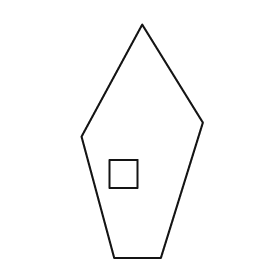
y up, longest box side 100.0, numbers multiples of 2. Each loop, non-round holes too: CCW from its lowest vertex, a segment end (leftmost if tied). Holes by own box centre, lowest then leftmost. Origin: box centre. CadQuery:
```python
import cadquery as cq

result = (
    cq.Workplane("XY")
    .moveTo(-12.0, -50.0)
    .lineTo(8.0, -50.0)
    .lineTo(26.0, 8.0)
    .lineTo(0.0, 50.0)
    .lineTo(-26.0, 2.0)
    .close()
    .moveTo(-14.0, -20.0)
    .lineTo(-2.0, -20.0)
    .lineTo(-2.0, -8.0)
    .lineTo(-14.0, -8.0)
    .close()
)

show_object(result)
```